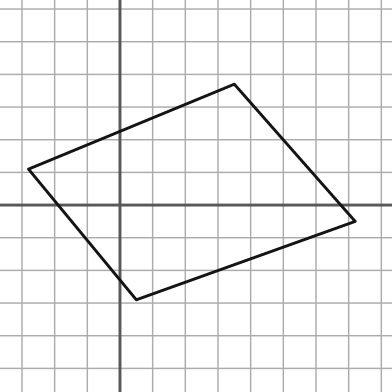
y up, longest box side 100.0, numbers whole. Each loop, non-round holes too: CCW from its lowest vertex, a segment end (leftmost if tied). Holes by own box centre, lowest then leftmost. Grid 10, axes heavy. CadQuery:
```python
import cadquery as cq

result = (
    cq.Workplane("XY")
    .moveTo(5.0, -29.0)
    .lineTo(72.0, -5.0)
    .lineTo(35.0, 37.0)
    .lineTo(-28.0, 11.0)
    .close()
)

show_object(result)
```